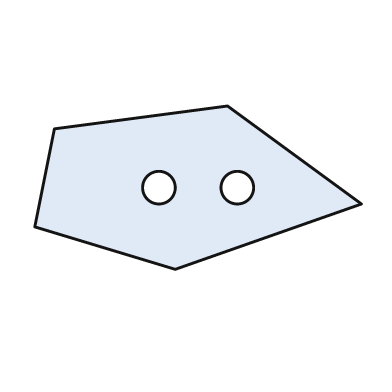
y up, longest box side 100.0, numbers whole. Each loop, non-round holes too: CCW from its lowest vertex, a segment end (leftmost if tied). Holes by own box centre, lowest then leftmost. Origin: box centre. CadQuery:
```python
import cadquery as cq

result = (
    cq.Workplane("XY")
    .moveTo(-7.0, -25.0)
    .lineTo(50.0, -5.0)
    .lineTo(9.0, 25.0)
    .lineTo(-44.0, 18.0)
    .lineTo(-50.0, -12.0)
    .close()
    .moveTo(-12.0, 0.0)
    .circle(5.0)
    .moveTo(12.0, 0.0)
    .circle(5.0)
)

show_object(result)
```